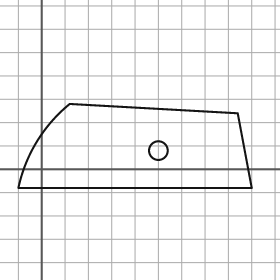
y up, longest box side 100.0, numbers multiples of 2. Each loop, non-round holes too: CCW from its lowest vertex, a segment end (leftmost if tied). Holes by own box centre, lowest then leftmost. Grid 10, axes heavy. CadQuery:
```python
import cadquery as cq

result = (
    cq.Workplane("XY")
    .moveTo(-10.0, -8.0)
    .lineTo(90.0, -8.0)
    .lineTo(84.0, 24.0)
    .lineTo(12.0, 28.0)
    .threePointArc((-2.0, 12.0), (-10.0, -8.0))
    .close()
    .moveTo(50.0, 8.0)
    .circle(4.0)
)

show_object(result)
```